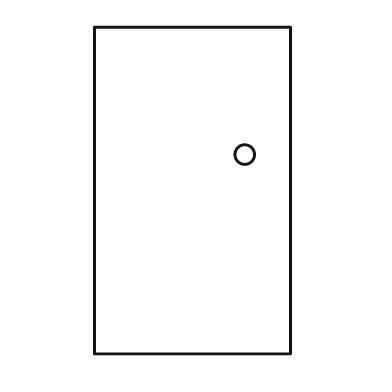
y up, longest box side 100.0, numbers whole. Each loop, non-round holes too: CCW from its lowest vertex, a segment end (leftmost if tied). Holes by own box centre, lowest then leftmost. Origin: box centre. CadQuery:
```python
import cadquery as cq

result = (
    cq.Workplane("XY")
    .moveTo(-30.0, -50.0)
    .lineTo(30.0, -50.0)
    .lineTo(30.0, 50.0)
    .lineTo(-30.0, 50.0)
    .close()
    .moveTo(16.0, 11.0)
    .circle(3.0)
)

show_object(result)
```